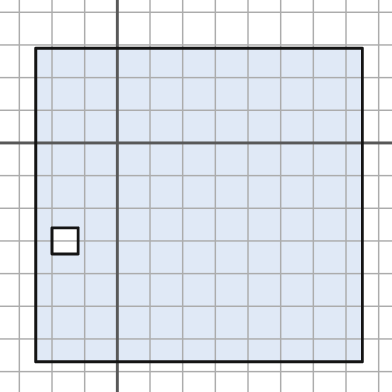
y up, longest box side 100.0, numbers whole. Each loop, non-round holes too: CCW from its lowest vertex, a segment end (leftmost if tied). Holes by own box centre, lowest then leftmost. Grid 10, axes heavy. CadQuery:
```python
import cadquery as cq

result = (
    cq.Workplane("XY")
    .moveTo(-25.0, -67.0)
    .lineTo(75.0, -67.0)
    .lineTo(75.0, 29.0)
    .lineTo(-25.0, 29.0)
    .close()
    .moveTo(-20.0, -34.0)
    .lineTo(-12.0, -34.0)
    .lineTo(-12.0, -26.0)
    .lineTo(-20.0, -26.0)
    .close()
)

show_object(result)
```